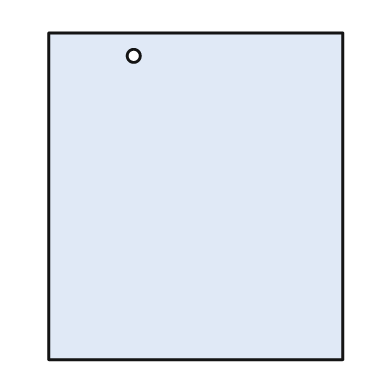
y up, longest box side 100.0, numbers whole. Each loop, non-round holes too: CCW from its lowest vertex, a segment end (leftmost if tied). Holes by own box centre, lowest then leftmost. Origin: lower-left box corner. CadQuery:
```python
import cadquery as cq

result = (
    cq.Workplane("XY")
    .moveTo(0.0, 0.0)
    .lineTo(90.0, 0.0)
    .lineTo(90.0, 100.0)
    .lineTo(0.0, 100.0)
    .close()
    .moveTo(26.0, 93.0)
    .circle(2.0)
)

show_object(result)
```